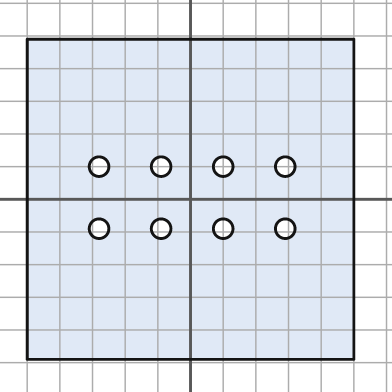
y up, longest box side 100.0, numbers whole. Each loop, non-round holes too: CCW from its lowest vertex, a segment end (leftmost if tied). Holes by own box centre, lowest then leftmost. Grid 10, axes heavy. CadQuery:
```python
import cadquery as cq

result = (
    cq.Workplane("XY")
    .moveTo(-50.0, -49.0)
    .lineTo(50.0, -49.0)
    .lineTo(50.0, 49.0)
    .lineTo(-50.0, 49.0)
    .close()
    .moveTo(-28.0, -9.0)
    .circle(3.0)
    .moveTo(-9.0, -9.0)
    .circle(3.0)
    .moveTo(10.0, -9.0)
    .circle(3.0)
    .moveTo(29.0, -9.0)
    .circle(3.0)
    .moveTo(-28.0, 10.0)
    .circle(3.0)
    .moveTo(-9.0, 10.0)
    .circle(3.0)
    .moveTo(10.0, 10.0)
    .circle(3.0)
    .moveTo(29.0, 10.0)
    .circle(3.0)
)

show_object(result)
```